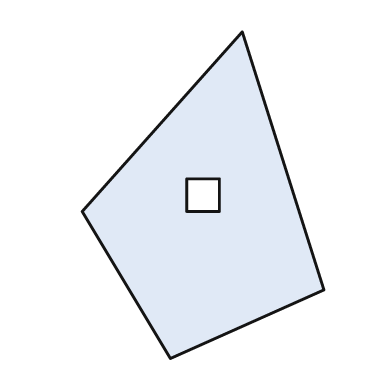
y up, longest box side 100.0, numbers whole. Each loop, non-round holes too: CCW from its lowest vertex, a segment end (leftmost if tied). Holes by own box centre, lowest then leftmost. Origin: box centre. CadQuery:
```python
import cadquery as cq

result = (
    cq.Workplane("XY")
    .moveTo(-10.0, -50.0)
    .lineTo(37.0, -29.0)
    .lineTo(12.0, 50.0)
    .lineTo(-37.0, -5.0)
    .close()
    .moveTo(-5.0, -5.0)
    .lineTo(5.0, -5.0)
    .lineTo(5.0, 5.0)
    .lineTo(-5.0, 5.0)
    .close()
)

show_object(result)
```